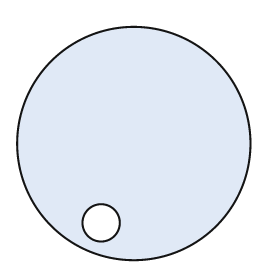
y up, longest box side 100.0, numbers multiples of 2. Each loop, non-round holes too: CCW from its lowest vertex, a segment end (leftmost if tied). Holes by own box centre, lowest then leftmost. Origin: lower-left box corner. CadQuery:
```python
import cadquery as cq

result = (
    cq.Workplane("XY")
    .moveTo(50.0, 50.0)
    .circle(50.0)
    .moveTo(36.0, 16.0)
    .circle(8.0)
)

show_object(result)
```